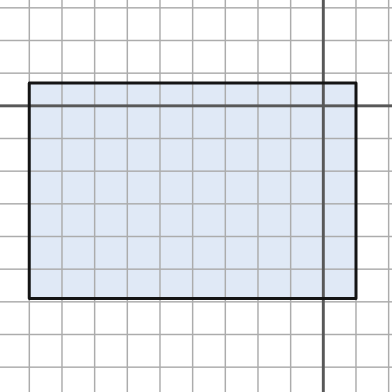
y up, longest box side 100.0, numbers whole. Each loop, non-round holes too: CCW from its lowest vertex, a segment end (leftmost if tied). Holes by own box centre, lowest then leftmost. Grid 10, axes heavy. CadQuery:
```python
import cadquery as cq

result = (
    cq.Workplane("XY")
    .moveTo(-90.0, -59.0)
    .lineTo(10.0, -59.0)
    .lineTo(10.0, 7.0)
    .lineTo(-90.0, 7.0)
    .close()
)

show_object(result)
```